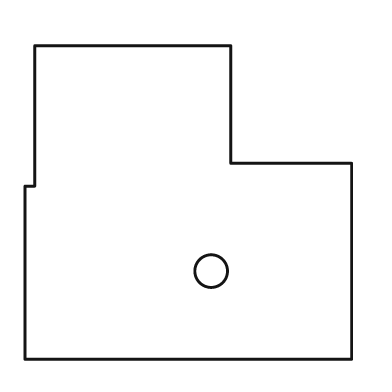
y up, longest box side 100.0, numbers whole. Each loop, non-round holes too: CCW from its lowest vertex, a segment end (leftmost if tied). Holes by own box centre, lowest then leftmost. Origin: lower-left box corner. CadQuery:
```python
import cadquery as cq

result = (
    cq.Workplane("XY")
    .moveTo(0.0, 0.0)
    .lineTo(100.0, 0.0)
    .lineTo(100.0, 60.0)
    .lineTo(63.0, 60.0)
    .lineTo(63.0, 96.0)
    .lineTo(3.0, 96.0)
    .lineTo(3.0, 53.0)
    .lineTo(0.0, 53.0)
    .close()
    .moveTo(57.0, 27.0)
    .circle(5.0)
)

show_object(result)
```